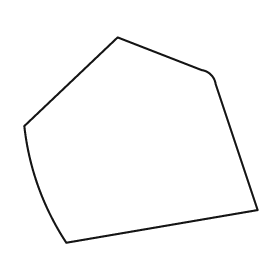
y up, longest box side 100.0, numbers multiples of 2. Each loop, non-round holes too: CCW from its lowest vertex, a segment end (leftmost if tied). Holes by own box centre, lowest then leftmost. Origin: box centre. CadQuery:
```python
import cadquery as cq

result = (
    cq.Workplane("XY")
    .moveTo(-32.0, -44.0)
    .lineTo(50.0, -30.0)
    .lineTo(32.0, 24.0)
    .threePointArc((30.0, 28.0), (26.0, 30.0))
    .lineTo(-10.0, 44.0)
    .lineTo(-50.0, 6.0)
    .threePointArc((-44.0, -20.0), (-32.0, -44.0))
    .close()
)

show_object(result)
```